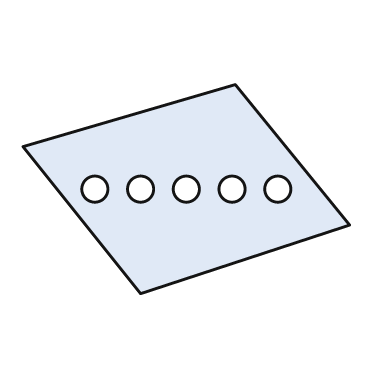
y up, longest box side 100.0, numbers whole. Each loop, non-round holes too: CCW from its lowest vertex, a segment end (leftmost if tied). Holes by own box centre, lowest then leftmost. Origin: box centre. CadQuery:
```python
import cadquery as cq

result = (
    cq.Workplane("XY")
    .moveTo(-14.0, -32.0)
    .lineTo(50.0, -11.0)
    .lineTo(15.0, 32.0)
    .lineTo(-50.0, 13.0)
    .close()
    .moveTo(-28.0, 0.0)
    .circle(4.0)
    .moveTo(-14.0, 0.0)
    .circle(4.0)
    .moveTo(0.0, 0.0)
    .circle(4.0)
    .moveTo(14.0, 0.0)
    .circle(4.0)
    .moveTo(28.0, 0.0)
    .circle(4.0)
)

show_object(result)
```